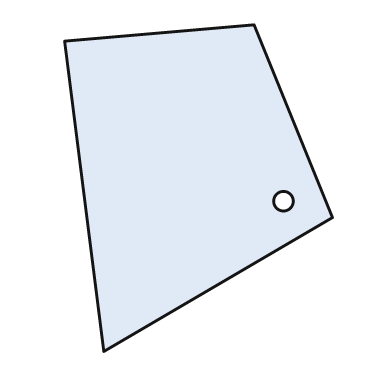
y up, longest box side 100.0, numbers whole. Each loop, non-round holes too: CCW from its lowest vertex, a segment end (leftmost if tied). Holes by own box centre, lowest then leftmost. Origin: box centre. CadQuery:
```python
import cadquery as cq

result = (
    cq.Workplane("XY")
    .moveTo(-29.0, -50.0)
    .lineTo(41.0, -9.0)
    .lineTo(17.0, 50.0)
    .lineTo(-41.0, 45.0)
    .close()
    .moveTo(26.0, -4.0)
    .circle(3.0)
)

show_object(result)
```